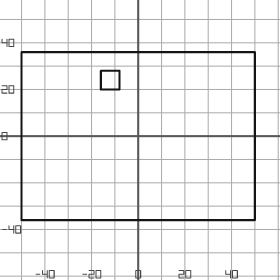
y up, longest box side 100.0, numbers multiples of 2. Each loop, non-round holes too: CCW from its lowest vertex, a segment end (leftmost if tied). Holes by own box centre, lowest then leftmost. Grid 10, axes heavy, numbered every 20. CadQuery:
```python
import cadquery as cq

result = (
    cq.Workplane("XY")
    .moveTo(-50.0, -36.0)
    .lineTo(50.0, -36.0)
    .lineTo(50.0, 36.0)
    .lineTo(-50.0, 36.0)
    .close()
    .moveTo(-16.0, 20.0)
    .lineTo(-8.0, 20.0)
    .lineTo(-8.0, 28.0)
    .lineTo(-16.0, 28.0)
    .close()
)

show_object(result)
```